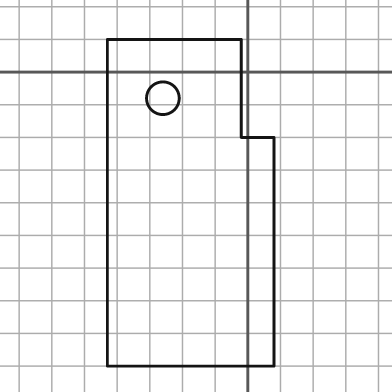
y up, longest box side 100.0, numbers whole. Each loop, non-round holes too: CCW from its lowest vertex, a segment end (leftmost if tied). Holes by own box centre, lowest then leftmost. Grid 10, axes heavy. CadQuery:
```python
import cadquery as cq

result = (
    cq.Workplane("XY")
    .moveTo(-43.0, -90.0)
    .lineTo(8.0, -90.0)
    .lineTo(8.0, -20.0)
    .lineTo(-2.0, -20.0)
    .lineTo(-2.0, 10.0)
    .lineTo(-43.0, 10.0)
    .close()
    .moveTo(-26.0, -8.0)
    .circle(5.0)
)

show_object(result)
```